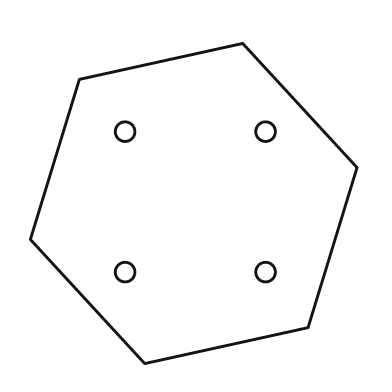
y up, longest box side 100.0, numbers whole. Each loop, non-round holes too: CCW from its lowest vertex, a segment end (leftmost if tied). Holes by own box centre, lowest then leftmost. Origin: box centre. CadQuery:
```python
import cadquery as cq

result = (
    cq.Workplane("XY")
    .moveTo(-15.0, -49.0)
    .lineTo(35.0, -38.0)
    .lineTo(50.0, 11.0)
    .lineTo(15.0, 49.0)
    .lineTo(-35.0, 38.0)
    .lineTo(-50.0, -11.0)
    .close()
    .moveTo(-21.0, -21.0)
    .circle(3.0)
    .moveTo(22.0, -21.0)
    .circle(3.0)
    .moveTo(-21.0, 22.0)
    .circle(3.0)
    .moveTo(22.0, 22.0)
    .circle(3.0)
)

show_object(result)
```